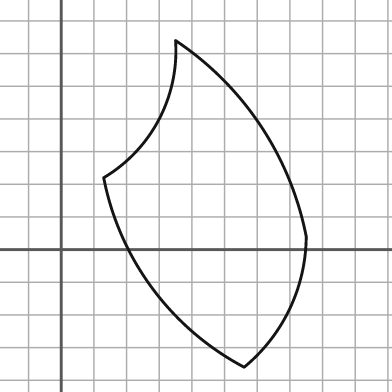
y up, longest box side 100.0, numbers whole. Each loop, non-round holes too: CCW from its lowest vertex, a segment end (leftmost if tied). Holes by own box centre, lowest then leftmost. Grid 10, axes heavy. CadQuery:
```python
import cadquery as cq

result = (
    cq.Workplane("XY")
    .moveTo(56.0, -36.0)
    .threePointArc((70.0, -18.0), (75.0, 4.0))
    .threePointArc((61.0, 38.0), (35.0, 64.0))
    .threePointArc((30.0, 40.0), (13.0, 22.0))
    .threePointArc((28.0, -12.0), (56.0, -36.0))
    .close()
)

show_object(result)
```